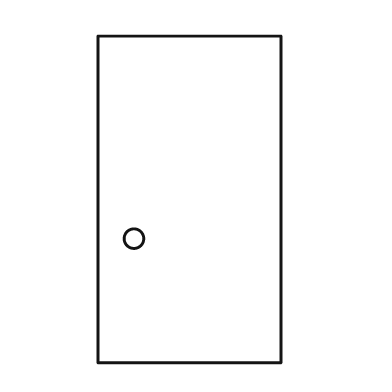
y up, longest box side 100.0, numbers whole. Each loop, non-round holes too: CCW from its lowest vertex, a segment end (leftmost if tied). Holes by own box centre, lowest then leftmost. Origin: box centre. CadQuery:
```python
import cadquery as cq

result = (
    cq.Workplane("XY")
    .moveTo(-28.0, -50.0)
    .lineTo(28.0, -50.0)
    .lineTo(28.0, 50.0)
    .lineTo(-28.0, 50.0)
    .close()
    .moveTo(-17.0, -12.0)
    .circle(3.0)
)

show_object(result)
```